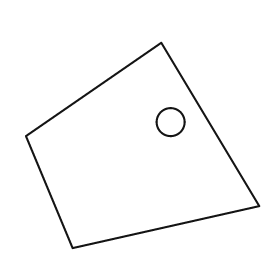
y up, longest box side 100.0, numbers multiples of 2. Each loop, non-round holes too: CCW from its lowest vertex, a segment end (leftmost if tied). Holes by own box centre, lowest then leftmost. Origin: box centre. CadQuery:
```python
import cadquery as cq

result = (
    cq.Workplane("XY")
    .moveTo(-30.0, -44.0)
    .lineTo(50.0, -26.0)
    .lineTo(8.0, 44.0)
    .lineTo(-50.0, 4.0)
    .close()
    .moveTo(12.0, 10.0)
    .circle(6.0)
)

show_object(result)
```